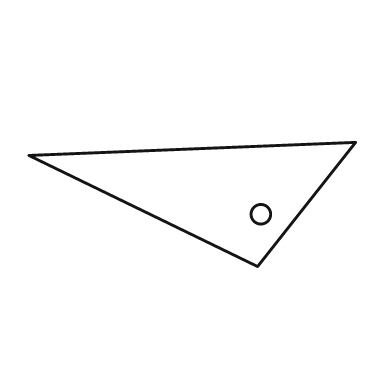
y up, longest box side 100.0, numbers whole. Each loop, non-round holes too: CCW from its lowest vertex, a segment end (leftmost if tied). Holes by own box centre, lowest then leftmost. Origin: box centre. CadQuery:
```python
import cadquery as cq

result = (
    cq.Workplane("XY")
    .moveTo(20.0, -19.0)
    .lineTo(50.0, 19.0)
    .lineTo(-50.0, 15.0)
    .close()
    .moveTo(21.0, -3.0)
    .circle(3.0)
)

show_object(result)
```